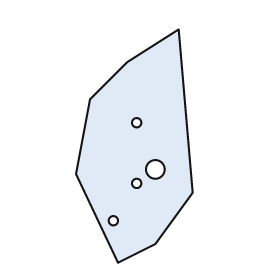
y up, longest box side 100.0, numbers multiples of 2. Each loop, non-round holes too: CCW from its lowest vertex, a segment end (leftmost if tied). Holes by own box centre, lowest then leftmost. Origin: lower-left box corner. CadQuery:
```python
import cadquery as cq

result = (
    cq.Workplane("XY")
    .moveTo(18.0, 0.0)
    .lineTo(34.0, 8.0)
    .lineTo(50.0, 30.0)
    .lineTo(44.0, 100.0)
    .lineTo(22.0, 86.0)
    .lineTo(6.0, 70.0)
    .lineTo(0.0, 38.0)
    .close()
    .moveTo(16.0, 18.0)
    .circle(2.0)
    .moveTo(26.0, 34.0)
    .circle(2.0)
    .moveTo(34.0, 40.0)
    .circle(4.0)
    .moveTo(26.0, 60.0)
    .circle(2.0)
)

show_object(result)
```